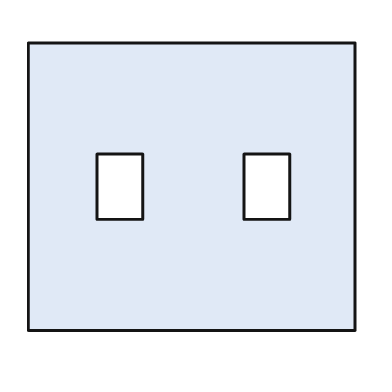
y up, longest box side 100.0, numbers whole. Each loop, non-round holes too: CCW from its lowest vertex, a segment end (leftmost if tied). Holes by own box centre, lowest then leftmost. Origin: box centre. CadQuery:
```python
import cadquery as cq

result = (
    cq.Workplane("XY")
    .moveTo(-50.0, -44.0)
    .lineTo(50.0, -44.0)
    .lineTo(50.0, 44.0)
    .lineTo(-50.0, 44.0)
    .close()
    .moveTo(-29.0, -10.0)
    .lineTo(-15.0, -10.0)
    .lineTo(-15.0, 10.0)
    .lineTo(-29.0, 10.0)
    .close()
    .moveTo(16.0, -10.0)
    .lineTo(30.0, -10.0)
    .lineTo(30.0, 10.0)
    .lineTo(16.0, 10.0)
    .close()
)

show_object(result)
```